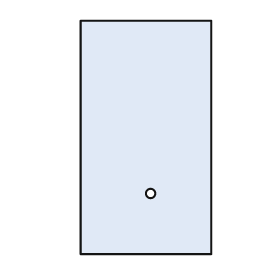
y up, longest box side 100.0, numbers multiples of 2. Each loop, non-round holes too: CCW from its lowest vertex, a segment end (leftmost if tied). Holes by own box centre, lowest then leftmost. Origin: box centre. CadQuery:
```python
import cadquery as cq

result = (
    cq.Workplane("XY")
    .moveTo(-28.0, -50.0)
    .lineTo(28.0, -50.0)
    .lineTo(28.0, 50.0)
    .lineTo(-28.0, 50.0)
    .close()
    .moveTo(2.0, -24.0)
    .circle(2.0)
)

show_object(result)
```